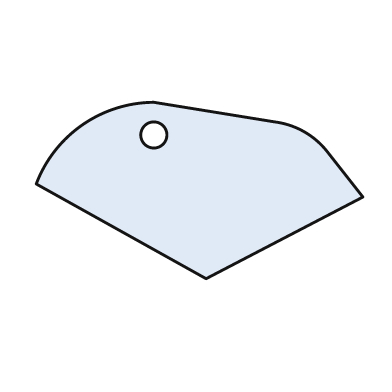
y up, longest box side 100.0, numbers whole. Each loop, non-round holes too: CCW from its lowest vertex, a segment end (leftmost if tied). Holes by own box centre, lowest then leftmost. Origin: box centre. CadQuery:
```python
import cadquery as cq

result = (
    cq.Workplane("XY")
    .moveTo(2.0, -27.0)
    .lineTo(50.0, -2.0)
    .lineTo(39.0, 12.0)
    .threePointArc((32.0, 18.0), (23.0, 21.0))
    .lineTo(-14.0, 27.0)
    .threePointArc((-36.0, 20.0), (-50.0, 2.0))
    .close()
    .moveTo(-14.0, 17.0)
    .circle(4.0)
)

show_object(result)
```